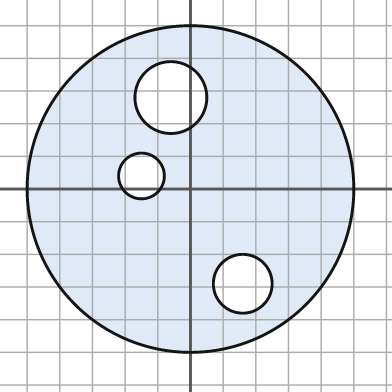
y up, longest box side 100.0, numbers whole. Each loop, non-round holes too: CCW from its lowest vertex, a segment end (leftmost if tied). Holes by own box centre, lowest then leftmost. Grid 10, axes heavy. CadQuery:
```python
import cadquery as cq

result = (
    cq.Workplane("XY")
    .moveTo(0.0, 0.0)
    .circle(50.0)
    .moveTo(16.0, -29.0)
    .circle(9.0)
    .moveTo(-15.0, 4.0)
    .circle(7.0)
    .moveTo(-6.0, 28.0)
    .circle(11.0)
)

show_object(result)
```